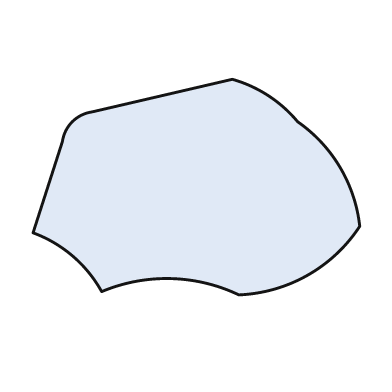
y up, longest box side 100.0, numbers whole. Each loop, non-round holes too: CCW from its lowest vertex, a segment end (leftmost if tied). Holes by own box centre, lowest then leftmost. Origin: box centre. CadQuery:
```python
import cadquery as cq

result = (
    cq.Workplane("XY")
    .moveTo(13.0, -33.0)
    .threePointArc((34.0, -27.0), (50.0, -12.0))
    .threePointArc((44.0, 6.0), (31.0, 20.0))
    .threePointArc((22.0, 28.0), (11.0, 33.0))
    .lineTo(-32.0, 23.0)
    .threePointArc((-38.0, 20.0), (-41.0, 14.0))
    .lineTo(-50.0, -14.0)
    .threePointArc((-38.0, -21.0), (-29.0, -32.0))
    .threePointArc((-8.0, -28.0), (13.0, -33.0))
    .close()
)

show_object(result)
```